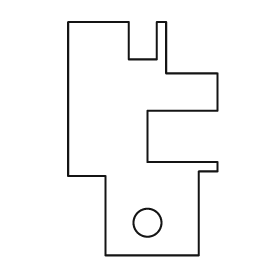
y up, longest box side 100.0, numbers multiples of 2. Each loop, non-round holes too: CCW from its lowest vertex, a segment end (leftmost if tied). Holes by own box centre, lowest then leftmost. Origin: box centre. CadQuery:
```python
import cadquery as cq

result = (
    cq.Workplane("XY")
    .moveTo(-16.0, -50.0)
    .lineTo(24.0, -50.0)
    .lineTo(24.0, -14.0)
    .lineTo(32.0, -14.0)
    .lineTo(32.0, -10.0)
    .lineTo(2.0, -10.0)
    .lineTo(2.0, 12.0)
    .lineTo(32.0, 12.0)
    .lineTo(32.0, 28.0)
    .lineTo(10.0, 28.0)
    .lineTo(10.0, 50.0)
    .lineTo(6.0, 50.0)
    .lineTo(6.0, 34.0)
    .lineTo(-6.0, 34.0)
    .lineTo(-6.0, 50.0)
    .lineTo(-32.0, 50.0)
    .lineTo(-32.0, -16.0)
    .lineTo(-16.0, -16.0)
    .close()
    .moveTo(2.0, -36.0)
    .circle(6.0)
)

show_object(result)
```